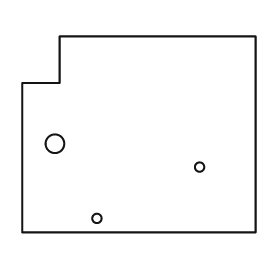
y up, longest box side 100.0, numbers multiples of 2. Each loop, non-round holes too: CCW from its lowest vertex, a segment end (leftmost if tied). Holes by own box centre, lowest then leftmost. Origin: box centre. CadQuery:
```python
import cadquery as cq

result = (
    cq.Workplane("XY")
    .moveTo(-50.0, -42.0)
    .lineTo(50.0, -42.0)
    .lineTo(50.0, 42.0)
    .lineTo(-34.0, 42.0)
    .lineTo(-34.0, 22.0)
    .lineTo(-50.0, 22.0)
    .close()
    .moveTo(-18.0, -36.0)
    .circle(2.0)
    .moveTo(26.0, -14.0)
    .circle(2.0)
    .moveTo(-36.0, -4.0)
    .circle(4.0)
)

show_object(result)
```